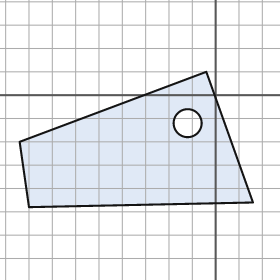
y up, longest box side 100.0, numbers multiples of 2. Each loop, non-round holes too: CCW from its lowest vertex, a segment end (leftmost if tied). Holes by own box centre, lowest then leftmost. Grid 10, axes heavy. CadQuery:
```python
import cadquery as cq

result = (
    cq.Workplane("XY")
    .moveTo(-80.0, -48.0)
    .lineTo(16.0, -46.0)
    .lineTo(-4.0, 10.0)
    .lineTo(-84.0, -20.0)
    .close()
    .moveTo(-12.0, -12.0)
    .circle(6.0)
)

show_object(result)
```